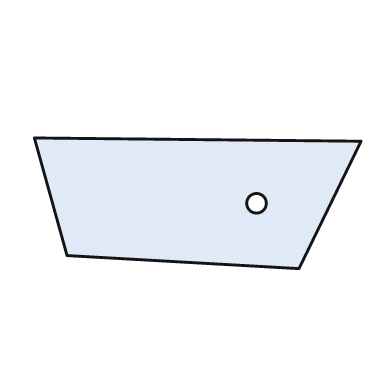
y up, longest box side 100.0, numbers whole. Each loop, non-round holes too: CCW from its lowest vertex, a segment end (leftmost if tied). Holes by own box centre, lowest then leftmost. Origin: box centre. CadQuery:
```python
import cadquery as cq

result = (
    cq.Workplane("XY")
    .moveTo(31.0, -20.0)
    .lineTo(50.0, 19.0)
    .lineTo(-50.0, 20.0)
    .lineTo(-40.0, -16.0)
    .close()
    .moveTo(18.0, 0.0)
    .circle(3.0)
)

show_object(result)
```